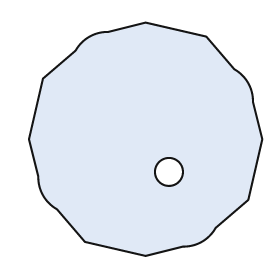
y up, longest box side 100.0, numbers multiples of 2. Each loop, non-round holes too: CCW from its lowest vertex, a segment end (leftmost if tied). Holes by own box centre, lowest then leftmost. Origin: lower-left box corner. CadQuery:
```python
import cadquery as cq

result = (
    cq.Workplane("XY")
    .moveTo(50.0, 0.0)
    .lineTo(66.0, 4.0)
    .threePointArc((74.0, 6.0), (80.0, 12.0))
    .lineTo(94.0, 24.0)
    .lineTo(100.0, 50.0)
    .lineTo(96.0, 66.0)
    .threePointArc((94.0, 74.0), (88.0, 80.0))
    .lineTo(76.0, 94.0)
    .lineTo(50.0, 100.0)
    .lineTo(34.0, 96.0)
    .threePointArc((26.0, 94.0), (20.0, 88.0))
    .lineTo(6.0, 76.0)
    .lineTo(0.0, 50.0)
    .lineTo(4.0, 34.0)
    .threePointArc((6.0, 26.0), (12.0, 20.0))
    .lineTo(24.0, 6.0)
    .close()
    .moveTo(60.0, 36.0)
    .circle(6.0)
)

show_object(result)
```